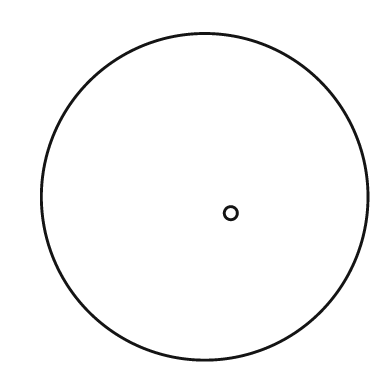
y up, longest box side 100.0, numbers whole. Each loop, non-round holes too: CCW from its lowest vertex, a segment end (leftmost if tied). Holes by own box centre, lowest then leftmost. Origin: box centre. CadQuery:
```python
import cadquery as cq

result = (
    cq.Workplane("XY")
    .moveTo(0.0, 0.0)
    .circle(50.0)
    .moveTo(8.0, -5.0)
    .circle(2.0)
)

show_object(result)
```